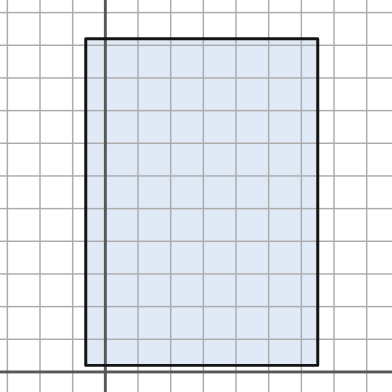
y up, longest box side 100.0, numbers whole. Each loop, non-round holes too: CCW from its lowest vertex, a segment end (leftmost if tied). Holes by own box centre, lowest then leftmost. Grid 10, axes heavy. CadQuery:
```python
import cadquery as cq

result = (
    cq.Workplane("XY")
    .moveTo(-6.0, 2.0)
    .lineTo(65.0, 2.0)
    .lineTo(65.0, 102.0)
    .lineTo(-6.0, 102.0)
    .close()
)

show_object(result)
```